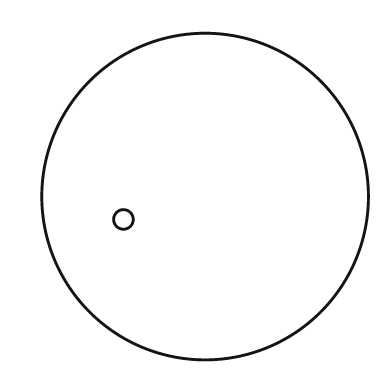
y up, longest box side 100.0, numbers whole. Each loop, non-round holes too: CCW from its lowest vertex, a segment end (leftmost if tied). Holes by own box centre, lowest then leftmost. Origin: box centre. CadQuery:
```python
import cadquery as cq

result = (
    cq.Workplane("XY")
    .moveTo(0.0, 0.0)
    .circle(50.0)
    .moveTo(-25.0, -7.0)
    .circle(3.0)
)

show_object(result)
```